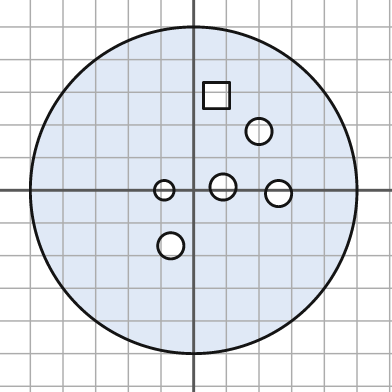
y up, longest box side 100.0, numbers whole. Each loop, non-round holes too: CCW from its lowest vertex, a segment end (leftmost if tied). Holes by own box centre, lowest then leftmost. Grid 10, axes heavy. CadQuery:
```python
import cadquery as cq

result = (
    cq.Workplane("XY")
    .moveTo(0.0, 0.0)
    .circle(50.0)
    .moveTo(-7.0, -17.0)
    .circle(4.0)
    .moveTo(26.0, -1.0)
    .circle(4.0)
    .moveTo(-9.0, 0.0)
    .circle(3.0)
    .moveTo(9.0, 1.0)
    .circle(4.0)
    .moveTo(20.0, 18.0)
    .circle(4.0)
    .moveTo(3.0, 25.0)
    .lineTo(11.0, 25.0)
    .lineTo(11.0, 33.0)
    .lineTo(3.0, 33.0)
    .close()
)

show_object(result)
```